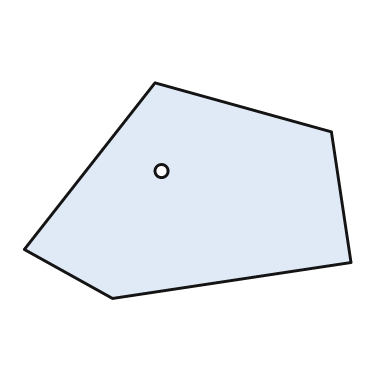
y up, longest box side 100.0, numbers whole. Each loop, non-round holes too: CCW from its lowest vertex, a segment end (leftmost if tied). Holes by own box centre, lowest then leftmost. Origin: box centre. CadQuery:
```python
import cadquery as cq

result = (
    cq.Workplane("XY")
    .moveTo(-23.0, -33.0)
    .lineTo(50.0, -22.0)
    .lineTo(44.0, 18.0)
    .lineTo(-10.0, 33.0)
    .lineTo(-50.0, -18.0)
    .close()
    .moveTo(-8.0, 6.0)
    .circle(2.0)
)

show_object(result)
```